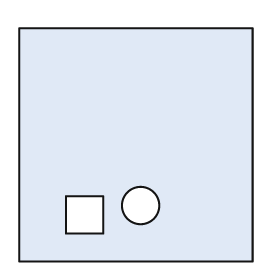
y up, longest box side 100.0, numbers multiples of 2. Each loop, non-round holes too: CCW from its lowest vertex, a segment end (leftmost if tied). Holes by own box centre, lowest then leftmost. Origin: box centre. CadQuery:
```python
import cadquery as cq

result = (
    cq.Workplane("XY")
    .moveTo(-50.0, -50.0)
    .lineTo(50.0, -50.0)
    .lineTo(50.0, 50.0)
    .lineTo(-50.0, 50.0)
    .close()
    .moveTo(-30.0, -38.0)
    .lineTo(-14.0, -38.0)
    .lineTo(-14.0, -22.0)
    .lineTo(-30.0, -22.0)
    .close()
    .moveTo(2.0, -26.0)
    .circle(8.0)
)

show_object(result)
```